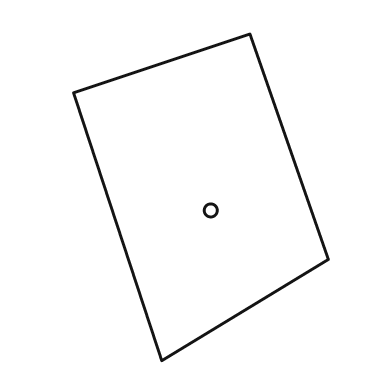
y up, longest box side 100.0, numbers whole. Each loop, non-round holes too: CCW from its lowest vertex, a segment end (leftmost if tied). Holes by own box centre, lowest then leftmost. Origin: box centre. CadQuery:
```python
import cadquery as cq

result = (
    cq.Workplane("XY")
    .moveTo(-12.0, -50.0)
    .lineTo(39.0, -19.0)
    .lineTo(15.0, 50.0)
    .lineTo(-39.0, 32.0)
    .close()
    .moveTo(3.0, -4.0)
    .circle(2.0)
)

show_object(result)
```